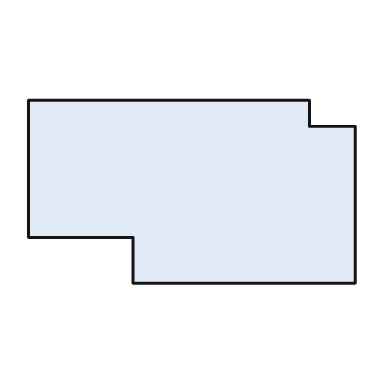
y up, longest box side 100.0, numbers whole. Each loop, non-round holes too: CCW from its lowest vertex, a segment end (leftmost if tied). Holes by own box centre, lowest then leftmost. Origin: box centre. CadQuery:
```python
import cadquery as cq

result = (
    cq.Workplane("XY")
    .moveTo(-18.0, -28.0)
    .lineTo(50.0, -28.0)
    .lineTo(50.0, 20.0)
    .lineTo(36.0, 20.0)
    .lineTo(36.0, 28.0)
    .lineTo(-50.0, 28.0)
    .lineTo(-50.0, -14.0)
    .lineTo(-18.0, -14.0)
    .close()
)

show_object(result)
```